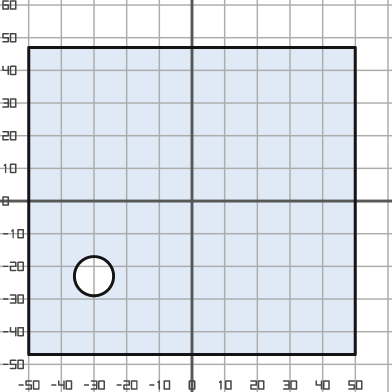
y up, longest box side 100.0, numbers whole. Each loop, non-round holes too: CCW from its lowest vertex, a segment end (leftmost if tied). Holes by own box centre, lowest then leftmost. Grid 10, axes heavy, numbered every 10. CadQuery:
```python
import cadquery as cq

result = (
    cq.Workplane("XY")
    .moveTo(-50.0, -47.0)
    .lineTo(50.0, -47.0)
    .lineTo(50.0, 47.0)
    .lineTo(-50.0, 47.0)
    .close()
    .moveTo(-30.0, -23.0)
    .circle(6.0)
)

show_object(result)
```